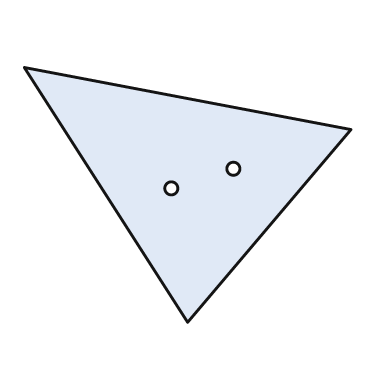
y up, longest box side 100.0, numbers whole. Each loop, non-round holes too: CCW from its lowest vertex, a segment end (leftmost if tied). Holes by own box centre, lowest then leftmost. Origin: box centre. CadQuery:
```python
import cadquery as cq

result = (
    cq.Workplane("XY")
    .moveTo(0.0, -39.0)
    .lineTo(50.0, 20.0)
    .lineTo(-50.0, 39.0)
    .close()
    .moveTo(-5.0, 2.0)
    .circle(2.0)
    .moveTo(14.0, 8.0)
    .circle(2.0)
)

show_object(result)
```